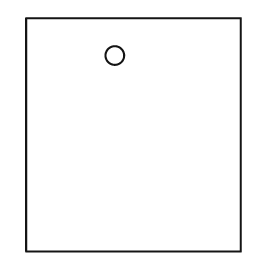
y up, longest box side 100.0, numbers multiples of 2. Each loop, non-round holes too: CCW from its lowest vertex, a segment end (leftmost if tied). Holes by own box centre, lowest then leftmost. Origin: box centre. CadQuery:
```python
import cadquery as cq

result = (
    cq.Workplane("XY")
    .moveTo(-46.0, -50.0)
    .lineTo(46.0, -50.0)
    .lineTo(46.0, 50.0)
    .lineTo(-46.0, 50.0)
    .close()
    .moveTo(-8.0, 34.0)
    .circle(4.0)
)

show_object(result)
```